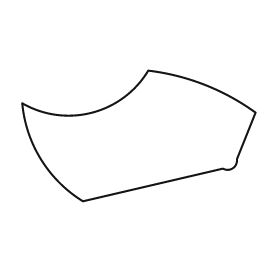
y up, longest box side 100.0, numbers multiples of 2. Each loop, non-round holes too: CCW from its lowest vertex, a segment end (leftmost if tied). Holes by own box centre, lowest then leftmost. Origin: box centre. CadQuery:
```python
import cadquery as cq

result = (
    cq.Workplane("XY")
    .moveTo(-24.0, -28.0)
    .lineTo(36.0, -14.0)
    .threePointArc((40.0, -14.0), (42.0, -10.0))
    .lineTo(50.0, 10.0)
    .threePointArc((28.0, 22.0), (4.0, 28.0))
    .threePointArc((-20.0, 10.0), (-50.0, 14.0))
    .threePointArc((-42.0, -10.0), (-24.0, -28.0))
    .close()
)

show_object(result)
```